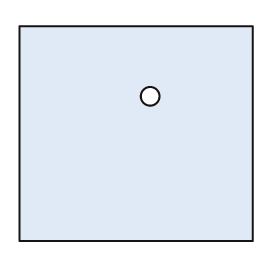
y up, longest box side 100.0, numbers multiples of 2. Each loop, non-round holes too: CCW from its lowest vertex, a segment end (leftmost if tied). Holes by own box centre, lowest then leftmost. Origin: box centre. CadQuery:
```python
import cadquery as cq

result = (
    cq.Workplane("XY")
    .moveTo(-50.0, -46.0)
    .lineTo(50.0, -46.0)
    .lineTo(50.0, 46.0)
    .lineTo(-50.0, 46.0)
    .close()
    .moveTo(6.0, 16.0)
    .circle(4.0)
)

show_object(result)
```